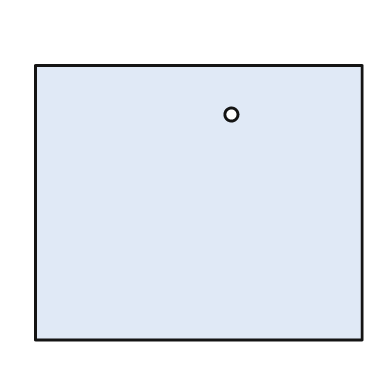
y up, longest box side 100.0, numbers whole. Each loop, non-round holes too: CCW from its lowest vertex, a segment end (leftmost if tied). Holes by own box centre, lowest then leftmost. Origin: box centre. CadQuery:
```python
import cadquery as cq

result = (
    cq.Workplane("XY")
    .moveTo(-50.0, -42.0)
    .lineTo(50.0, -42.0)
    .lineTo(50.0, 42.0)
    .lineTo(-50.0, 42.0)
    .close()
    .moveTo(10.0, 27.0)
    .circle(2.0)
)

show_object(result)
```